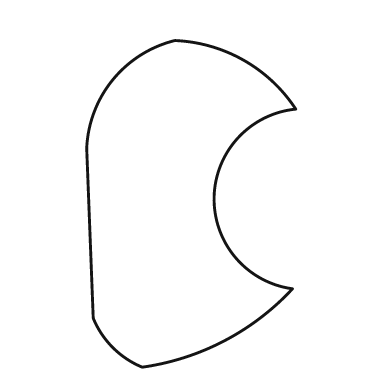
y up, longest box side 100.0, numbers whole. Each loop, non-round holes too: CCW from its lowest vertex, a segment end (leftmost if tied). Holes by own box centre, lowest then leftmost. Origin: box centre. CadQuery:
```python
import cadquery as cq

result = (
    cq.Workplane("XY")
    .moveTo(-15.0, -50.0)
    .threePointArc((10.0, -42.0), (31.0, -26.0))
    .threePointArc((7.0, 2.0), (32.0, 29.0))
    .threePointArc((16.0, 44.0), (-5.0, 50.0))
    .threePointArc((-24.0, 38.0), (-32.0, 17.0))
    .lineTo(-30.0, -35.0)
    .threePointArc((-24.0, -44.0), (-15.0, -50.0))
    .close()
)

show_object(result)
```